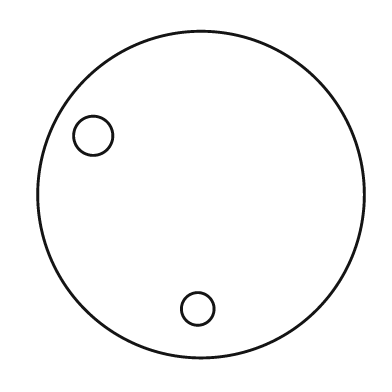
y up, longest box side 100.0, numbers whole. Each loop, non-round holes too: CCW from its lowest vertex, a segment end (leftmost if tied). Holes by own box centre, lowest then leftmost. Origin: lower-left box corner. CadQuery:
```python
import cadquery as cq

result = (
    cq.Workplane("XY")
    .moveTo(50.0, 50.0)
    .circle(50.0)
    .moveTo(49.0, 15.0)
    .circle(5.0)
    .moveTo(17.0, 68.0)
    .circle(6.0)
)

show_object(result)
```